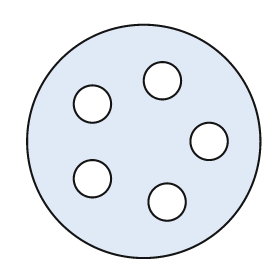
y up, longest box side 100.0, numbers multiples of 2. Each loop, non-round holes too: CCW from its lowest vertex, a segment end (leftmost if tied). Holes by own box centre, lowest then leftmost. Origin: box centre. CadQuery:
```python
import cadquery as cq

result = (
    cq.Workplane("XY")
    .moveTo(0.0, 0.0)
    .circle(50.0)
    .moveTo(10.0, -26.0)
    .circle(8.0)
    .moveTo(-22.0, -16.0)
    .circle(8.0)
    .moveTo(28.0, 0.0)
    .circle(8.0)
    .moveTo(-22.0, 16.0)
    .circle(8.0)
    .moveTo(8.0, 26.0)
    .circle(8.0)
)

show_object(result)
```